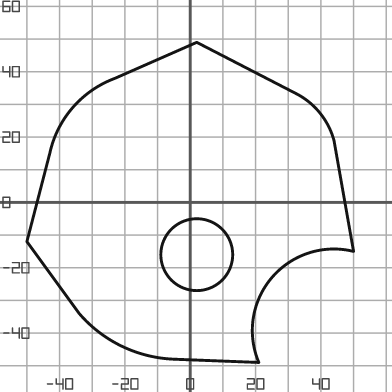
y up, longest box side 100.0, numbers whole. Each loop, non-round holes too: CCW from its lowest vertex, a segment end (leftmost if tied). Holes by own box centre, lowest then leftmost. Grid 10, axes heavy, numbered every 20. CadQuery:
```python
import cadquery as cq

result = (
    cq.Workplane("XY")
    .moveTo(21.0, -49.0)
    .threePointArc((25.0, -23.0), (50.0, -15.0))
    .lineTo(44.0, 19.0)
    .threePointArc((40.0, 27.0), (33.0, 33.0))
    .lineTo(2.0, 49.0)
    .lineTo(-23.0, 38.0)
    .threePointArc((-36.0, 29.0), (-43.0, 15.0))
    .lineTo(-50.0, -12.0)
    .lineTo(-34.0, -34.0)
    .threePointArc((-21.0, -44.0), (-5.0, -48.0))
    .close()
    .moveTo(2.0, -16.0)
    .circle(11.0)
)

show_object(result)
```